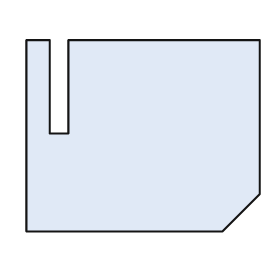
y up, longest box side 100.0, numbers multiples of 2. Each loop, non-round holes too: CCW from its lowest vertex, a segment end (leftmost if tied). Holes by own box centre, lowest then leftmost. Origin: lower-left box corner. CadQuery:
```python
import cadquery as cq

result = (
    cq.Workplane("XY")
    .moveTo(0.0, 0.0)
    .lineTo(84.0, 0.0)
    .lineTo(100.0, 16.0)
    .lineTo(100.0, 82.0)
    .lineTo(18.0, 82.0)
    .lineTo(18.0, 42.0)
    .lineTo(10.0, 42.0)
    .lineTo(10.0, 82.0)
    .lineTo(0.0, 82.0)
    .close()
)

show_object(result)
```